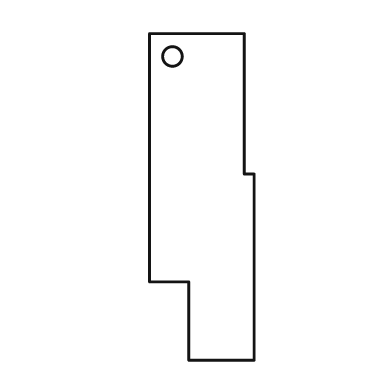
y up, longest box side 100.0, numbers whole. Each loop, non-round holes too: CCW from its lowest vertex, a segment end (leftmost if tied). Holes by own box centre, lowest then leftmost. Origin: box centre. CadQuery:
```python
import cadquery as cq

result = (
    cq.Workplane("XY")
    .moveTo(-4.0, -50.0)
    .lineTo(16.0, -50.0)
    .lineTo(16.0, 7.0)
    .lineTo(13.0, 7.0)
    .lineTo(13.0, 50.0)
    .lineTo(-16.0, 50.0)
    .lineTo(-16.0, -26.0)
    .lineTo(-4.0, -26.0)
    .close()
    .moveTo(-9.0, 43.0)
    .circle(3.0)
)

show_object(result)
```